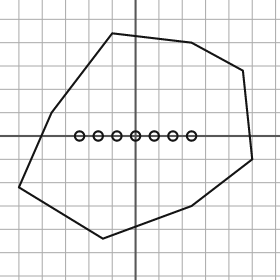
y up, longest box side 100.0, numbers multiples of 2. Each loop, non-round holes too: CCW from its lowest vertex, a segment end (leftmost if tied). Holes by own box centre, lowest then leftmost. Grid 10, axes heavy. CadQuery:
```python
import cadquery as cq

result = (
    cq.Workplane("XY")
    .moveTo(-14.0, -44.0)
    .lineTo(24.0, -30.0)
    .lineTo(50.0, -10.0)
    .lineTo(46.0, 28.0)
    .lineTo(24.0, 40.0)
    .lineTo(-10.0, 44.0)
    .lineTo(-36.0, 10.0)
    .lineTo(-50.0, -22.0)
    .close()
    .moveTo(-24.0, 0.0)
    .circle(2.0)
    .moveTo(-16.0, 0.0)
    .circle(2.0)
    .moveTo(-8.0, 0.0)
    .circle(2.0)
    .moveTo(0.0, 0.0)
    .circle(2.0)
    .moveTo(8.0, 0.0)
    .circle(2.0)
    .moveTo(16.0, 0.0)
    .circle(2.0)
    .moveTo(24.0, 0.0)
    .circle(2.0)
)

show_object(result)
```